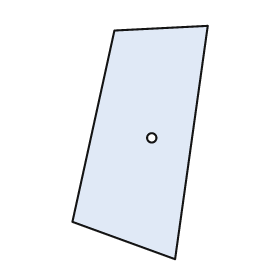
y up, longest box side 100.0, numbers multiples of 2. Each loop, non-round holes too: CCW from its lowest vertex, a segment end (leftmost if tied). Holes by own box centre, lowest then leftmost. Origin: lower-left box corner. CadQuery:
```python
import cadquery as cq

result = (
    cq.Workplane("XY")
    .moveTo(44.0, 0.0)
    .lineTo(58.0, 100.0)
    .lineTo(18.0, 98.0)
    .lineTo(0.0, 16.0)
    .close()
    .moveTo(34.0, 52.0)
    .circle(2.0)
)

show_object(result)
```